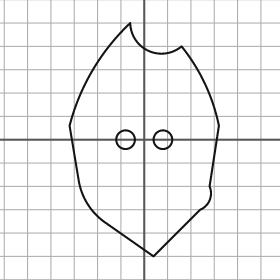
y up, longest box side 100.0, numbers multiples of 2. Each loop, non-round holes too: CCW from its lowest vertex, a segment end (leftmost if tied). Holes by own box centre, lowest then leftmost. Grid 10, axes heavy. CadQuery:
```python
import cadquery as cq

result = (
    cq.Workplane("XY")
    .moveTo(4.0, -50.0)
    .lineTo(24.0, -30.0)
    .threePointArc((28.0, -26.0), (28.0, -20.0))
    .lineTo(32.0, 6.0)
    .threePointArc((26.0, 24.0), (16.0, 40.0))
    .threePointArc((2.0, 38.0), (-6.0, 50.0))
    .threePointArc((-22.0, 30.0), (-32.0, 6.0))
    .lineTo(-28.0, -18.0)
    .threePointArc((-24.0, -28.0), (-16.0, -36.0))
    .close()
    .moveTo(-8.0, 0.0)
    .circle(4.0)
    .moveTo(8.0, 0.0)
    .circle(4.0)
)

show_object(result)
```